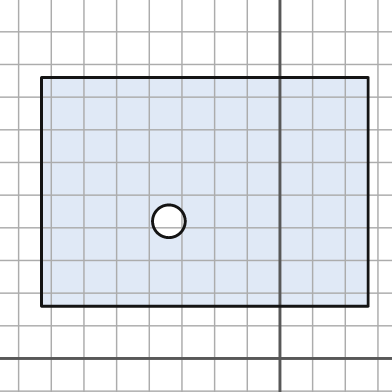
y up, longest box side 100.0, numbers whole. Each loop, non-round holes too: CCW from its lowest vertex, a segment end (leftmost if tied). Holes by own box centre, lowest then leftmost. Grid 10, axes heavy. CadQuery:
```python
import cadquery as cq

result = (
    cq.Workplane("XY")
    .moveTo(-73.0, 16.0)
    .lineTo(27.0, 16.0)
    .lineTo(27.0, 86.0)
    .lineTo(-73.0, 86.0)
    .close()
    .moveTo(-34.0, 42.0)
    .circle(5.0)
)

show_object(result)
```